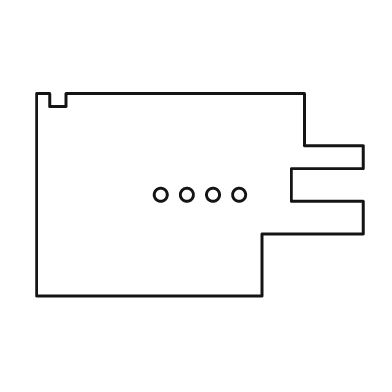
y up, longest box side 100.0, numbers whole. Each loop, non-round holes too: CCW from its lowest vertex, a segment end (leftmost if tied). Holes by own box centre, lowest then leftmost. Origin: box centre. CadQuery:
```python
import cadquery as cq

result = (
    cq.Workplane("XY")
    .moveTo(-50.0, -31.0)
    .lineTo(19.0, -31.0)
    .lineTo(19.0, -12.0)
    .lineTo(50.0, -12.0)
    .lineTo(50.0, -2.0)
    .lineTo(28.0, -2.0)
    .lineTo(28.0, 8.0)
    .lineTo(50.0, 8.0)
    .lineTo(50.0, 15.0)
    .lineTo(32.0, 15.0)
    .lineTo(32.0, 31.0)
    .lineTo(-41.0, 31.0)
    .lineTo(-41.0, 27.0)
    .lineTo(-46.0, 27.0)
    .lineTo(-46.0, 31.0)
    .lineTo(-50.0, 31.0)
    .close()
    .moveTo(-12.0, 0.0)
    .circle(2.0)
    .moveTo(-4.0, 0.0)
    .circle(2.0)
    .moveTo(4.0, 0.0)
    .circle(2.0)
    .moveTo(12.0, 0.0)
    .circle(2.0)
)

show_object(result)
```